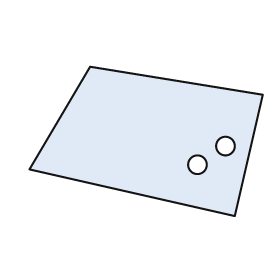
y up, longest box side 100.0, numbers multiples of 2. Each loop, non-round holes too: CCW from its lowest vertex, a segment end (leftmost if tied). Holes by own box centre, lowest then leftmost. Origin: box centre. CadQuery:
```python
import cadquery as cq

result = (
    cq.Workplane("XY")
    .moveTo(38.0, -32.0)
    .lineTo(50.0, 20.0)
    .lineTo(-24.0, 32.0)
    .lineTo(-50.0, -12.0)
    .close()
    .moveTo(22.0, -10.0)
    .circle(4.0)
    .moveTo(34.0, -2.0)
    .circle(4.0)
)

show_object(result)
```